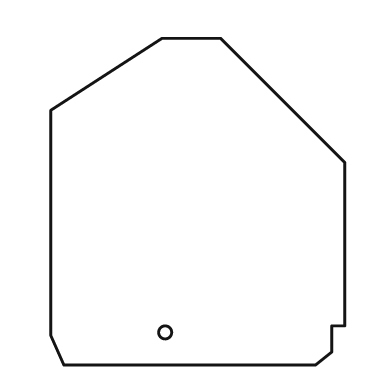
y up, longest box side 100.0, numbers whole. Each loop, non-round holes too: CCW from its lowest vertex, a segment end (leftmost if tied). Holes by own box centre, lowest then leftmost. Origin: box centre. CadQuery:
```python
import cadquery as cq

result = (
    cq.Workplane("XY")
    .moveTo(-41.0, -50.0)
    .lineTo(36.0, -50.0)
    .lineTo(41.0, -46.0)
    .lineTo(41.0, -38.0)
    .lineTo(45.0, -38.0)
    .lineTo(45.0, 12.0)
    .lineTo(7.0, 50.0)
    .lineTo(-11.0, 50.0)
    .lineTo(-45.0, 28.0)
    .lineTo(-45.0, -41.0)
    .close()
    .moveTo(-10.0, -40.0)
    .circle(2.0)
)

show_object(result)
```